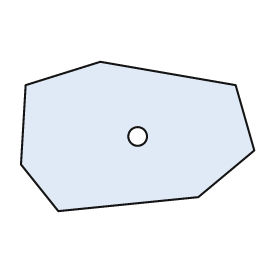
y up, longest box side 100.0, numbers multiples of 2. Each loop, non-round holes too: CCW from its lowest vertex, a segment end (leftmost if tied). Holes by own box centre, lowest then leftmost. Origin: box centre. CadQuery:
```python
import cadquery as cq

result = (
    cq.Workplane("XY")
    .moveTo(-34.0, -32.0)
    .lineTo(26.0, -26.0)
    .lineTo(50.0, -6.0)
    .lineTo(42.0, 22.0)
    .lineTo(-16.0, 32.0)
    .lineTo(-48.0, 22.0)
    .lineTo(-50.0, -12.0)
    .close()
    .moveTo(0.0, 0.0)
    .circle(4.0)
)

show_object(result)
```